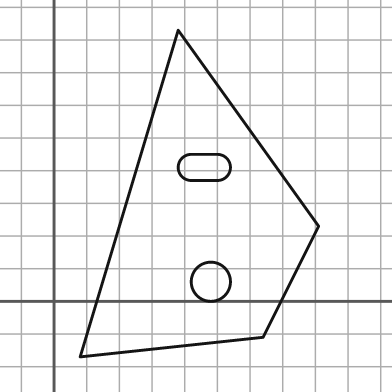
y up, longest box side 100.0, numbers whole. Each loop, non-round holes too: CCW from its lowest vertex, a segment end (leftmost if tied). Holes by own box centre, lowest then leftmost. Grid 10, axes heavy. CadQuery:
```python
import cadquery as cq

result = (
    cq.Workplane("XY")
    .moveTo(8.0, -17.0)
    .lineTo(64.0, -11.0)
    .lineTo(81.0, 23.0)
    .lineTo(38.0, 83.0)
    .close()
    .moveTo(48.0, 6.0)
    .circle(6.0)
    .moveTo(42.0, 37.0)
    .lineTo(50.0, 37.0)
    .threePointArc((54.0, 41.0), (50.0, 45.0))
    .lineTo(42.0, 45.0)
    .threePointArc((38.0, 41.0), (42.0, 37.0))
    .close()
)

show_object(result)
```